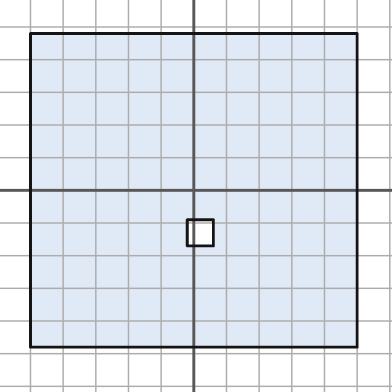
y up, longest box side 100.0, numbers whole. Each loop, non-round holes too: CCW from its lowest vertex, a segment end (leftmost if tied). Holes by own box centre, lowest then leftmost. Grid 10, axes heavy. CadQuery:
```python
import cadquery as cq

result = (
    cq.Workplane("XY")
    .moveTo(-50.0, -48.0)
    .lineTo(50.0, -48.0)
    .lineTo(50.0, 48.0)
    .lineTo(-50.0, 48.0)
    .close()
    .moveTo(-2.0, -17.0)
    .lineTo(6.0, -17.0)
    .lineTo(6.0, -9.0)
    .lineTo(-2.0, -9.0)
    .close()
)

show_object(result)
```